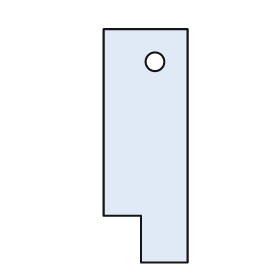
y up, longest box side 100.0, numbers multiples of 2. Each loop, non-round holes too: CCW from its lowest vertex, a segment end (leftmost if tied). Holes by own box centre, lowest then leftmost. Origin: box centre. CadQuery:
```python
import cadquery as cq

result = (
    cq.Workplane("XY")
    .moveTo(-2.0, -50.0)
    .lineTo(18.0, -50.0)
    .lineTo(18.0, 50.0)
    .lineTo(-18.0, 50.0)
    .lineTo(-18.0, -30.0)
    .lineTo(-2.0, -30.0)
    .close()
    .moveTo(4.0, 36.0)
    .circle(4.0)
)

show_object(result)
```